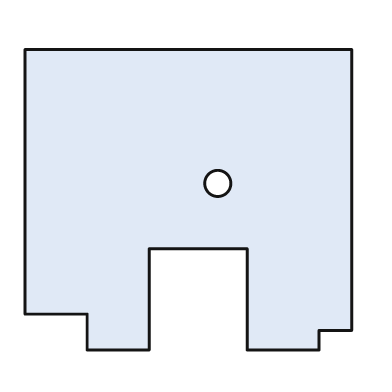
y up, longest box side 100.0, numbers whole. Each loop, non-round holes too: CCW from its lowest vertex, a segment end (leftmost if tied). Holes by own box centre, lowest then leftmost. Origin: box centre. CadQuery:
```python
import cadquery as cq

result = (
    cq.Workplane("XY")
    .moveTo(-31.0, -46.0)
    .lineTo(-12.0, -46.0)
    .lineTo(-12.0, -15.0)
    .lineTo(18.0, -15.0)
    .lineTo(18.0, -46.0)
    .lineTo(40.0, -46.0)
    .lineTo(40.0, -40.0)
    .lineTo(50.0, -40.0)
    .lineTo(50.0, 46.0)
    .lineTo(-50.0, 46.0)
    .lineTo(-50.0, -35.0)
    .lineTo(-31.0, -35.0)
    .close()
    .moveTo(9.0, 5.0)
    .circle(4.0)
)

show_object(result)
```